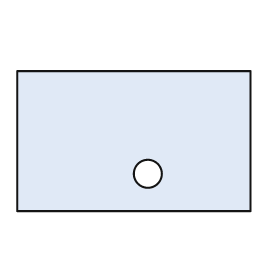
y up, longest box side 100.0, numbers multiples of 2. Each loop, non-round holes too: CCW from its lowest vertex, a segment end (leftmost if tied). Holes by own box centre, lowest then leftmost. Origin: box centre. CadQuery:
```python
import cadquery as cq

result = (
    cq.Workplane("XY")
    .moveTo(-50.0, -30.0)
    .lineTo(50.0, -30.0)
    .lineTo(50.0, 30.0)
    .lineTo(-50.0, 30.0)
    .close()
    .moveTo(6.0, -14.0)
    .circle(6.0)
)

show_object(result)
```